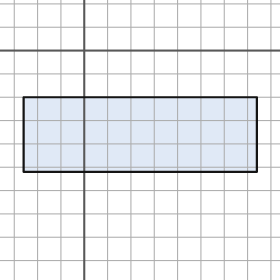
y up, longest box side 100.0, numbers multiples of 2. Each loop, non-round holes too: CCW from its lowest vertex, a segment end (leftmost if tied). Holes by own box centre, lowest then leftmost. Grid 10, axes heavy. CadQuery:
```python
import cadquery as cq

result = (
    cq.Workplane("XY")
    .moveTo(-26.0, -52.0)
    .lineTo(74.0, -52.0)
    .lineTo(74.0, -20.0)
    .lineTo(-26.0, -20.0)
    .close()
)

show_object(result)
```